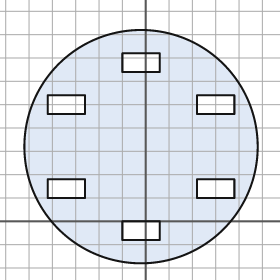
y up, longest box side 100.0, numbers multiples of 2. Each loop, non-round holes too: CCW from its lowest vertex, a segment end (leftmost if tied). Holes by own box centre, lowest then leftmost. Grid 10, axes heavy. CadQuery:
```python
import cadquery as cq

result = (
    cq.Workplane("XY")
    .moveTo(-2.0, 32.0)
    .circle(50.0)
    .moveTo(-10.0, -8.0)
    .lineTo(6.0, -8.0)
    .lineTo(6.0, 0.0)
    .lineTo(-10.0, 0.0)
    .close()
    .moveTo(-42.0, 10.0)
    .lineTo(-26.0, 10.0)
    .lineTo(-26.0, 18.0)
    .lineTo(-42.0, 18.0)
    .close()
    .moveTo(22.0, 10.0)
    .lineTo(38.0, 10.0)
    .lineTo(38.0, 18.0)
    .lineTo(22.0, 18.0)
    .close()
    .moveTo(-42.0, 46.0)
    .lineTo(-26.0, 46.0)
    .lineTo(-26.0, 54.0)
    .lineTo(-42.0, 54.0)
    .close()
    .moveTo(22.0, 46.0)
    .lineTo(38.0, 46.0)
    .lineTo(38.0, 54.0)
    .lineTo(22.0, 54.0)
    .close()
    .moveTo(-10.0, 64.0)
    .lineTo(6.0, 64.0)
    .lineTo(6.0, 72.0)
    .lineTo(-10.0, 72.0)
    .close()
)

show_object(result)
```